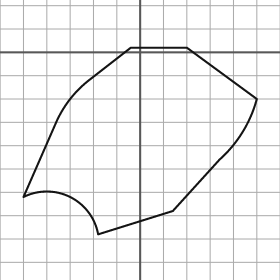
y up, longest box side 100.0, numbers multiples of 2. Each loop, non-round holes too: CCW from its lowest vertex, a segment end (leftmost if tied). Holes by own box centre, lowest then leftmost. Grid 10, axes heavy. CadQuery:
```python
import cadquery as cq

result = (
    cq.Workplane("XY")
    .moveTo(-18.0, -78.0)
    .lineTo(14.0, -68.0)
    .lineTo(34.0, -46.0)
    .threePointArc((44.0, -34.0), (50.0, -20.0))
    .lineTo(20.0, 2.0)
    .lineTo(-4.0, 2.0)
    .lineTo(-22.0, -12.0)
    .threePointArc((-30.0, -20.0), (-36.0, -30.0))
    .lineTo(-50.0, -62.0)
    .threePointArc((-30.0, -62.0), (-18.0, -78.0))
    .close()
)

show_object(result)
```